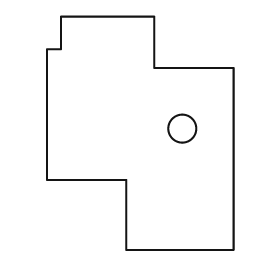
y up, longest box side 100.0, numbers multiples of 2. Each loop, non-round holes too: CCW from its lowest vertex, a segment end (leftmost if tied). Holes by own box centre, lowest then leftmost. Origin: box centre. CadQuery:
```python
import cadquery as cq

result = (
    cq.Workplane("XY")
    .moveTo(-6.0, -50.0)
    .lineTo(40.0, -50.0)
    .lineTo(40.0, 28.0)
    .lineTo(6.0, 28.0)
    .lineTo(6.0, 50.0)
    .lineTo(-34.0, 50.0)
    .lineTo(-34.0, 36.0)
    .lineTo(-40.0, 36.0)
    .lineTo(-40.0, -20.0)
    .lineTo(-6.0, -20.0)
    .close()
    .moveTo(18.0, 2.0)
    .circle(6.0)
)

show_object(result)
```